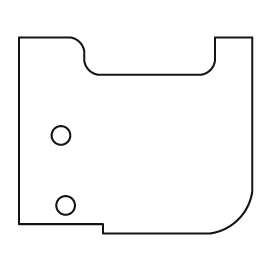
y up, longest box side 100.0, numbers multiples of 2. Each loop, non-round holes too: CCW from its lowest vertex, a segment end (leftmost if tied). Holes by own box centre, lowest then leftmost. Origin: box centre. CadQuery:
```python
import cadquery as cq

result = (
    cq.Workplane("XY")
    .moveTo(-14.0, -42.0)
    .lineTo(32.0, -42.0)
    .threePointArc((44.0, -36.0), (50.0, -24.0))
    .lineTo(50.0, 42.0)
    .lineTo(34.0, 42.0)
    .lineTo(34.0, 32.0)
    .threePointArc((32.0, 28.0), (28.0, 26.0))
    .lineTo(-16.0, 26.0)
    .threePointArc((-20.0, 28.0), (-22.0, 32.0))
    .lineTo(-22.0, 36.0)
    .threePointArc((-24.0, 40.0), (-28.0, 42.0))
    .lineTo(-50.0, 42.0)
    .lineTo(-50.0, -38.0)
    .lineTo(-14.0, -38.0)
    .close()
    .moveTo(-30.0, -30.0)
    .circle(4.0)
    .moveTo(-32.0, 0.0)
    .circle(4.0)
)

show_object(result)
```